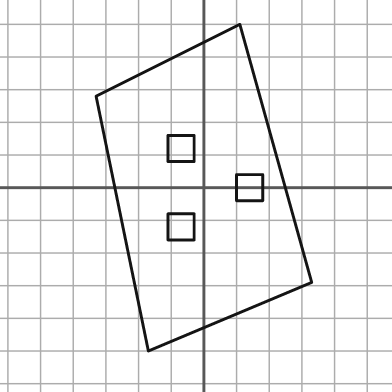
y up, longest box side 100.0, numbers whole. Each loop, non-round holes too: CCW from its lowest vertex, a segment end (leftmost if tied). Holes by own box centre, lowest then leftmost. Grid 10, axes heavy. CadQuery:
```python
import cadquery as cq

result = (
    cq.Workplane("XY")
    .moveTo(-17.0, -50.0)
    .lineTo(33.0, -29.0)
    .lineTo(11.0, 50.0)
    .lineTo(-33.0, 28.0)
    .close()
    .moveTo(-11.0, -16.0)
    .lineTo(-3.0, -16.0)
    .lineTo(-3.0, -8.0)
    .lineTo(-11.0, -8.0)
    .close()
    .moveTo(10.0, -4.0)
    .lineTo(18.0, -4.0)
    .lineTo(18.0, 4.0)
    .lineTo(10.0, 4.0)
    .close()
    .moveTo(-11.0, 8.0)
    .lineTo(-3.0, 8.0)
    .lineTo(-3.0, 16.0)
    .lineTo(-11.0, 16.0)
    .close()
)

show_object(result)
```